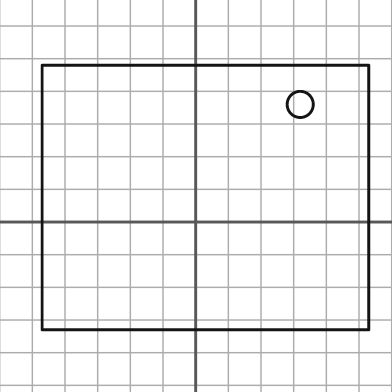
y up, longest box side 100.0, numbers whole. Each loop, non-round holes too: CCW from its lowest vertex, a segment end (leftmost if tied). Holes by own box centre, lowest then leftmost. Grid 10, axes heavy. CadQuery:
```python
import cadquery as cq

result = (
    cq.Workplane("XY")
    .moveTo(-47.0, -33.0)
    .lineTo(53.0, -33.0)
    .lineTo(53.0, 48.0)
    .lineTo(-47.0, 48.0)
    .close()
    .moveTo(32.0, 36.0)
    .circle(4.0)
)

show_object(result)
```